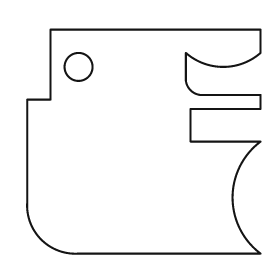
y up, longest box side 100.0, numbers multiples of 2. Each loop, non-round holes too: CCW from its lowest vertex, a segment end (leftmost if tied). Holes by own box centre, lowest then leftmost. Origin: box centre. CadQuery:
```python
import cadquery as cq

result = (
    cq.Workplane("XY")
    .moveTo(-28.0, -48.0)
    .lineTo(50.0, -48.0)
    .threePointArc((38.0, -24.0), (50.0, 0.0))
    .lineTo(20.0, 0.0)
    .lineTo(20.0, 14.0)
    .lineTo(50.0, 14.0)
    .lineTo(50.0, 20.0)
    .lineTo(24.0, 20.0)
    .threePointArc((20.0, 22.0), (18.0, 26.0))
    .lineTo(18.0, 38.0)
    .threePointArc((34.0, 32.0), (50.0, 38.0))
    .lineTo(50.0, 48.0)
    .lineTo(-40.0, 48.0)
    .lineTo(-40.0, 18.0)
    .lineTo(-50.0, 18.0)
    .lineTo(-50.0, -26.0)
    .threePointArc((-44.0, -42.0), (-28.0, -48.0))
    .close()
    .moveTo(-28.0, 32.0)
    .circle(6.0)
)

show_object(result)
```